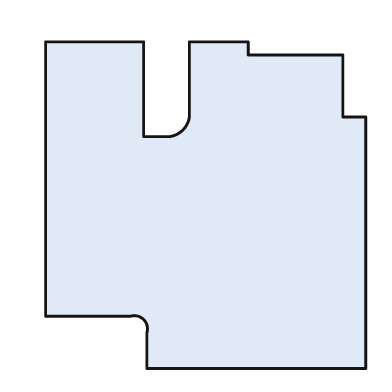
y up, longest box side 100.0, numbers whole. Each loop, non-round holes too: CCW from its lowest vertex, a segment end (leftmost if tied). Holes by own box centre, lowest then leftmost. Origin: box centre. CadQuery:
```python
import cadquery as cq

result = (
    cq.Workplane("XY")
    .moveTo(-18.0, -50.0)
    .lineTo(49.0, -50.0)
    .lineTo(49.0, 27.0)
    .lineTo(42.0, 27.0)
    .lineTo(42.0, 46.0)
    .lineTo(13.0, 46.0)
    .lineTo(13.0, 50.0)
    .lineTo(-5.0, 50.0)
    .lineTo(-5.0, 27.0)
    .threePointArc((-7.0, 23.0), (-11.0, 21.0))
    .lineTo(-19.0, 21.0)
    .lineTo(-19.0, 50.0)
    .lineTo(-49.0, 50.0)
    .lineTo(-49.0, -34.0)
    .lineTo(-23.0, -34.0)
    .threePointArc((-19.0, -35.0), (-18.0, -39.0))
    .close()
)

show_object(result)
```